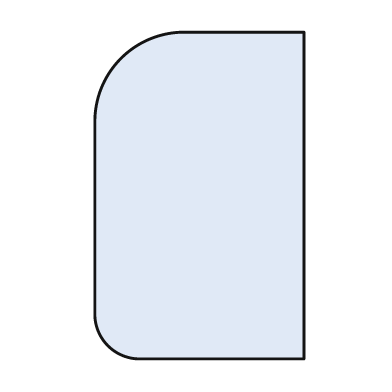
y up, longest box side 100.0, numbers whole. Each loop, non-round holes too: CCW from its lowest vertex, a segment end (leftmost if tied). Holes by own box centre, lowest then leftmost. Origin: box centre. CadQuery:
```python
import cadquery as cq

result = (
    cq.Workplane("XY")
    .moveTo(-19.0, -50.0)
    .lineTo(32.0, -50.0)
    .lineTo(32.0, 50.0)
    .lineTo(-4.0, 50.0)
    .threePointArc((-24.0, 42.0), (-32.0, 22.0))
    .lineTo(-32.0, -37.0)
    .threePointArc((-28.0, -46.0), (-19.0, -50.0))
    .close()
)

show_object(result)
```